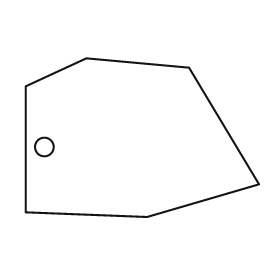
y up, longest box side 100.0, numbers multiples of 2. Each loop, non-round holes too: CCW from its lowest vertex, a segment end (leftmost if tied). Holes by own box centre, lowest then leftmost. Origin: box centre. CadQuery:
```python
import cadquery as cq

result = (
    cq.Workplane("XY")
    .moveTo(2.0, -34.0)
    .lineTo(50.0, -20.0)
    .lineTo(20.0, 30.0)
    .lineTo(-24.0, 34.0)
    .lineTo(-50.0, 22.0)
    .lineTo(-50.0, -32.0)
    .close()
    .moveTo(-42.0, -4.0)
    .circle(4.0)
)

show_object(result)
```